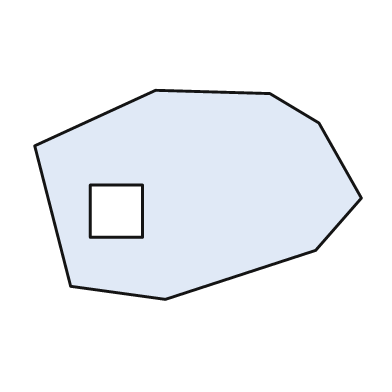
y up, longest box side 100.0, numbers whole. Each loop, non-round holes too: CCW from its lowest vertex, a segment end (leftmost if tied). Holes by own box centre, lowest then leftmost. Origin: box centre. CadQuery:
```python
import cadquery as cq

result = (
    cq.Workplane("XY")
    .moveTo(-10.0, -32.0)
    .lineTo(36.0, -17.0)
    .lineTo(50.0, -1.0)
    .lineTo(37.0, 22.0)
    .lineTo(22.0, 31.0)
    .lineTo(-13.0, 32.0)
    .lineTo(-50.0, 15.0)
    .lineTo(-39.0, -28.0)
    .close()
    .moveTo(-33.0, -13.0)
    .lineTo(-17.0, -13.0)
    .lineTo(-17.0, 3.0)
    .lineTo(-33.0, 3.0)
    .close()
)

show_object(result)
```